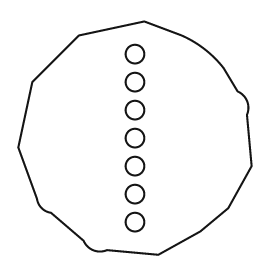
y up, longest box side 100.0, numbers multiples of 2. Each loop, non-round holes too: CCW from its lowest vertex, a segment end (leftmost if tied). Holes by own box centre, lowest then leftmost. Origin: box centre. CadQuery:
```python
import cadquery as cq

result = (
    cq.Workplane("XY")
    .moveTo(10.0, -50.0)
    .lineTo(28.0, -40.0)
    .lineTo(40.0, -30.0)
    .lineTo(50.0, -12.0)
    .lineTo(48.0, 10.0)
    .threePointArc((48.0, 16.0), (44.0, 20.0))
    .lineTo(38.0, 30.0)
    .threePointArc((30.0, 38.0), (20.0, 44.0))
    .lineTo(4.0, 50.0)
    .lineTo(-24.0, 44.0)
    .lineTo(-44.0, 24.0)
    .lineTo(-50.0, -4.0)
    .lineTo(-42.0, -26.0)
    .threePointArc((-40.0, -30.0), (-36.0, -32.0))
    .lineTo(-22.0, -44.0)
    .threePointArc((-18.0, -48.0), (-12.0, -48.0))
    .close()
    .moveTo(0.0, -36.0)
    .circle(4.0)
    .moveTo(0.0, -24.0)
    .circle(4.0)
    .moveTo(0.0, -12.0)
    .circle(4.0)
    .moveTo(0.0, 0.0)
    .circle(4.0)
    .moveTo(0.0, 12.0)
    .circle(4.0)
    .moveTo(0.0, 24.0)
    .circle(4.0)
    .moveTo(0.0, 36.0)
    .circle(4.0)
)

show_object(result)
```